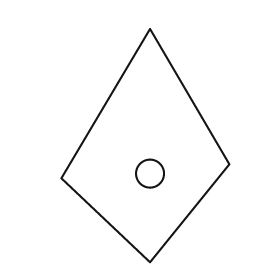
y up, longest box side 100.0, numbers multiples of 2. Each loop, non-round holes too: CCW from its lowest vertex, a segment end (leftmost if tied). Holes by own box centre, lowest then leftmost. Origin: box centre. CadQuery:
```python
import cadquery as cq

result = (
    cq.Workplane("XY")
    .moveTo(2.0, -50.0)
    .lineTo(36.0, -8.0)
    .lineTo(2.0, 50.0)
    .lineTo(-36.0, -14.0)
    .close()
    .moveTo(2.0, -12.0)
    .circle(6.0)
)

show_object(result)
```